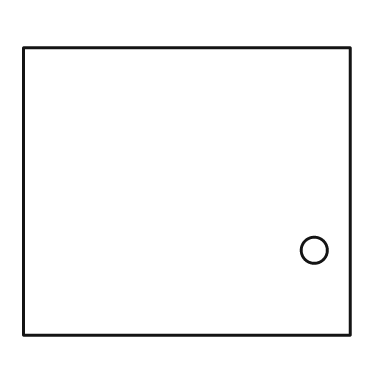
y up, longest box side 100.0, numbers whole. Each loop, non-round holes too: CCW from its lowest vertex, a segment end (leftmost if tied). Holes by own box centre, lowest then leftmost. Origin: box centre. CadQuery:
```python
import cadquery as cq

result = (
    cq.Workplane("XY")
    .moveTo(-50.0, -44.0)
    .lineTo(50.0, -44.0)
    .lineTo(50.0, 44.0)
    .lineTo(-50.0, 44.0)
    .close()
    .moveTo(39.0, -18.0)
    .circle(4.0)
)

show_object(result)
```